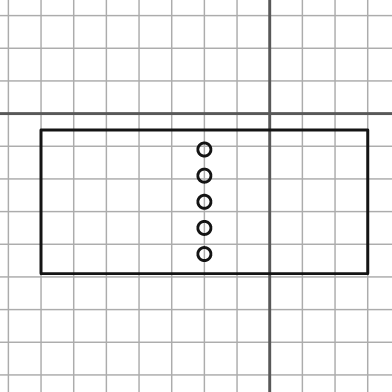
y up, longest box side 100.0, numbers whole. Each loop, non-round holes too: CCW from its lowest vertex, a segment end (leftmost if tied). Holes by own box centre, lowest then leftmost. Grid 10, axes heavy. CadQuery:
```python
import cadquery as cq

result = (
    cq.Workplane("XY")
    .moveTo(-70.0, -49.0)
    .lineTo(30.0, -49.0)
    .lineTo(30.0, -5.0)
    .lineTo(-70.0, -5.0)
    .close()
    .moveTo(-20.0, -43.0)
    .circle(2.0)
    .moveTo(-20.0, -35.0)
    .circle(2.0)
    .moveTo(-20.0, -27.0)
    .circle(2.0)
    .moveTo(-20.0, -19.0)
    .circle(2.0)
    .moveTo(-20.0, -11.0)
    .circle(2.0)
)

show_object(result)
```